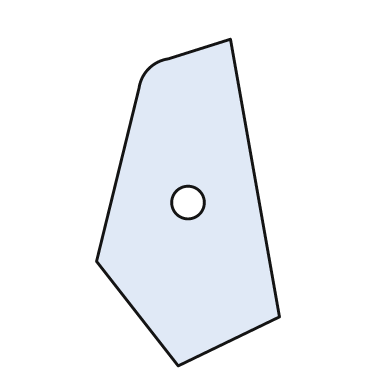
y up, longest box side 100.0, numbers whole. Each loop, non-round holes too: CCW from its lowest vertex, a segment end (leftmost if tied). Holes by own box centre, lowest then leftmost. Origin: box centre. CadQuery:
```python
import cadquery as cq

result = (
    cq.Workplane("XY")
    .moveTo(-3.0, -50.0)
    .lineTo(28.0, -35.0)
    .lineTo(13.0, 50.0)
    .lineTo(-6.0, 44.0)
    .threePointArc((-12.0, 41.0), (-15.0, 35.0))
    .lineTo(-28.0, -18.0)
    .close()
    .moveTo(0.0, 0.0)
    .circle(5.0)
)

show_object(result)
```